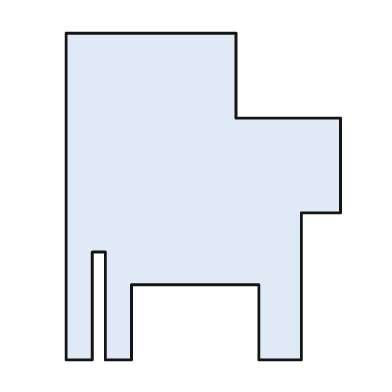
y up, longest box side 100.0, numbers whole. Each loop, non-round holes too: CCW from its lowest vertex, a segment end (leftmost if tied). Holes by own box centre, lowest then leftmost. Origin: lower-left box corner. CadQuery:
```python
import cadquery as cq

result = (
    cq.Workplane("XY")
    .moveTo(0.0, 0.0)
    .lineTo(8.0, 0.0)
    .lineTo(8.0, 33.0)
    .lineTo(12.0, 33.0)
    .lineTo(12.0, 0.0)
    .lineTo(20.0, 0.0)
    .lineTo(20.0, 23.0)
    .lineTo(59.0, 23.0)
    .lineTo(59.0, 0.0)
    .lineTo(72.0, 0.0)
    .lineTo(72.0, 45.0)
    .lineTo(84.0, 45.0)
    .lineTo(84.0, 74.0)
    .lineTo(52.0, 74.0)
    .lineTo(52.0, 100.0)
    .lineTo(0.0, 100.0)
    .close()
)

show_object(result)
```